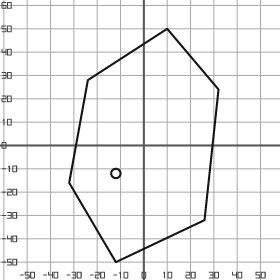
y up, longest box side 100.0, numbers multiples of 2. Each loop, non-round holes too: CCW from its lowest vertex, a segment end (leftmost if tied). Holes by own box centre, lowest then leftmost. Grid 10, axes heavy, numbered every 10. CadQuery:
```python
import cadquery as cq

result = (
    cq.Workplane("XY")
    .moveTo(-12.0, -50.0)
    .lineTo(26.0, -32.0)
    .lineTo(32.0, 24.0)
    .lineTo(10.0, 50.0)
    .lineTo(-24.0, 28.0)
    .lineTo(-32.0, -16.0)
    .close()
    .moveTo(-12.0, -12.0)
    .circle(2.0)
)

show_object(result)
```